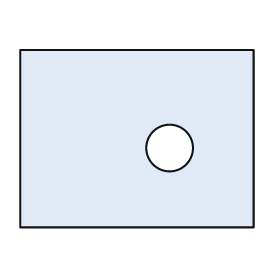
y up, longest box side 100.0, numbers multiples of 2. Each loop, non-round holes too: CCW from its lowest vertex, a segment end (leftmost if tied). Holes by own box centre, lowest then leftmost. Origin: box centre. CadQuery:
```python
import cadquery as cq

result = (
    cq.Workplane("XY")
    .moveTo(-50.0, -38.0)
    .lineTo(50.0, -38.0)
    .lineTo(50.0, 38.0)
    .lineTo(-50.0, 38.0)
    .close()
    .moveTo(14.0, -4.0)
    .circle(10.0)
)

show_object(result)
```